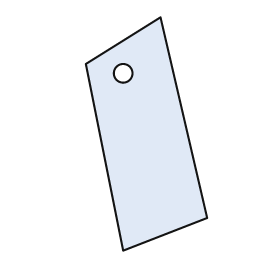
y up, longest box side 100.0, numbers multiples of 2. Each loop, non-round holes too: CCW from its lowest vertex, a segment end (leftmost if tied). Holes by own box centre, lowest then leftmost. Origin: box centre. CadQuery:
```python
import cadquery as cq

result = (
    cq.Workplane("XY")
    .moveTo(-10.0, -50.0)
    .lineTo(26.0, -36.0)
    .lineTo(6.0, 50.0)
    .lineTo(-26.0, 30.0)
    .close()
    .moveTo(-10.0, 26.0)
    .circle(4.0)
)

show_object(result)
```